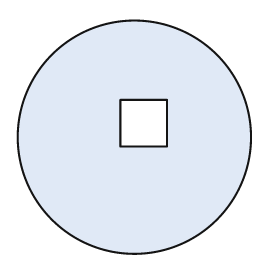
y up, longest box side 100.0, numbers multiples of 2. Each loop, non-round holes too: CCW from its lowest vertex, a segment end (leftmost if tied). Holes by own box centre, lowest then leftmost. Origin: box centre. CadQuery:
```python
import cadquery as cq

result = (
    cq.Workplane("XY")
    .moveTo(0.0, 0.0)
    .circle(50.0)
    .moveTo(-6.0, -4.0)
    .lineTo(14.0, -4.0)
    .lineTo(14.0, 16.0)
    .lineTo(-6.0, 16.0)
    .close()
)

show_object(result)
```